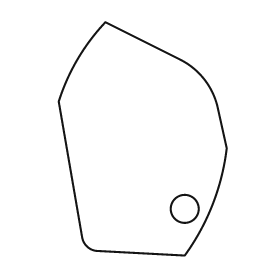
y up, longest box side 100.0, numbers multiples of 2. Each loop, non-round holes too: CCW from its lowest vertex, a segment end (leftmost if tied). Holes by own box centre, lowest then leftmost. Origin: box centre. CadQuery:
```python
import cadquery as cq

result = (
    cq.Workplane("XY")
    .moveTo(18.0, -50.0)
    .threePointArc((30.0, -28.0), (36.0, -4.0))
    .lineTo(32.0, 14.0)
    .threePointArc((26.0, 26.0), (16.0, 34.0))
    .lineTo(-16.0, 50.0)
    .threePointArc((-28.0, 34.0), (-36.0, 16.0))
    .lineTo(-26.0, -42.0)
    .threePointArc((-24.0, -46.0), (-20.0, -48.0))
    .close()
    .moveTo(18.0, -30.0)
    .circle(6.0)
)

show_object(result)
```